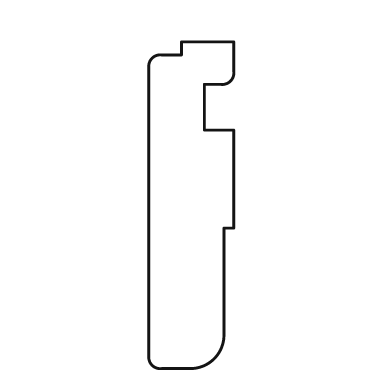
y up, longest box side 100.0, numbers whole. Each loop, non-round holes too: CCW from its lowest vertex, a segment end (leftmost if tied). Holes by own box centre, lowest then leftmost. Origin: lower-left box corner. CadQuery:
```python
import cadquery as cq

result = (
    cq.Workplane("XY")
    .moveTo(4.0, 0.0)
    .lineTo(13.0, 0.0)
    .threePointArc((20.0, 3.0), (23.0, 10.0))
    .lineTo(23.0, 43.0)
    .lineTo(26.0, 43.0)
    .lineTo(26.0, 73.0)
    .lineTo(17.0, 73.0)
    .lineTo(17.0, 87.0)
    .lineTo(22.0, 87.0)
    .threePointArc((25.0, 88.0), (26.0, 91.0))
    .lineTo(26.0, 100.0)
    .lineTo(10.0, 100.0)
    .lineTo(10.0, 96.0)
    .lineTo(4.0, 96.0)
    .threePointArc((1.0, 95.0), (0.0, 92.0))
    .lineTo(0.0, 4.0)
    .threePointArc((1.0, 1.0), (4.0, 0.0))
    .close()
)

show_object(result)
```